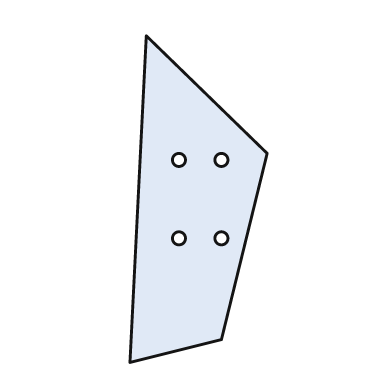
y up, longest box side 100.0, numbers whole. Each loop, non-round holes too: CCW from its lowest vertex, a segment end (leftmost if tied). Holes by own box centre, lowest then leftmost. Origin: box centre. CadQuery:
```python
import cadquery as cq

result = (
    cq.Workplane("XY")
    .moveTo(-21.0, -50.0)
    .lineTo(7.0, -43.0)
    .lineTo(21.0, 14.0)
    .lineTo(-16.0, 50.0)
    .close()
    .moveTo(-6.0, -12.0)
    .circle(2.0)
    .moveTo(7.0, -12.0)
    .circle(2.0)
    .moveTo(-6.0, 12.0)
    .circle(2.0)
    .moveTo(7.0, 12.0)
    .circle(2.0)
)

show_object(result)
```